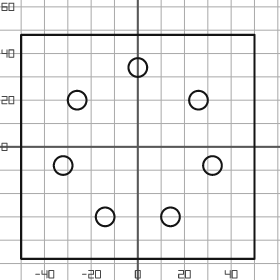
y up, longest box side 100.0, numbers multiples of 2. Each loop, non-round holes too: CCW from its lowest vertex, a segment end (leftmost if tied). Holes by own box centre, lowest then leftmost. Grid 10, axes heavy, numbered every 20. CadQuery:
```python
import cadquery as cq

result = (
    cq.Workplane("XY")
    .moveTo(-50.0, -48.0)
    .lineTo(50.0, -48.0)
    .lineTo(50.0, 48.0)
    .lineTo(-50.0, 48.0)
    .close()
    .moveTo(-14.0, -30.0)
    .circle(4.0)
    .moveTo(14.0, -30.0)
    .circle(4.0)
    .moveTo(-32.0, -8.0)
    .circle(4.0)
    .moveTo(32.0, -8.0)
    .circle(4.0)
    .moveTo(-26.0, 20.0)
    .circle(4.0)
    .moveTo(26.0, 20.0)
    .circle(4.0)
    .moveTo(0.0, 34.0)
    .circle(4.0)
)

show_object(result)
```